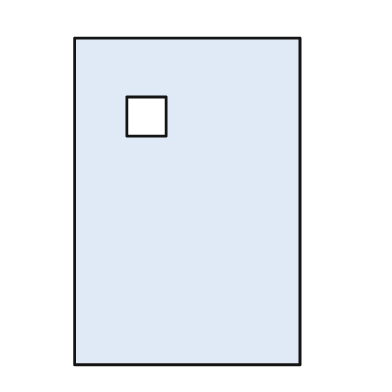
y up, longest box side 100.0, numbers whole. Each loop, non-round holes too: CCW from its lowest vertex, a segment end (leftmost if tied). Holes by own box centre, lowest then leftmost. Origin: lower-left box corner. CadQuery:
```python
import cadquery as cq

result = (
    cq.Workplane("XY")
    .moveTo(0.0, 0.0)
    .lineTo(69.0, 0.0)
    .lineTo(69.0, 100.0)
    .lineTo(0.0, 100.0)
    .close()
    .moveTo(16.0, 70.0)
    .lineTo(28.0, 70.0)
    .lineTo(28.0, 82.0)
    .lineTo(16.0, 82.0)
    .close()
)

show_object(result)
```